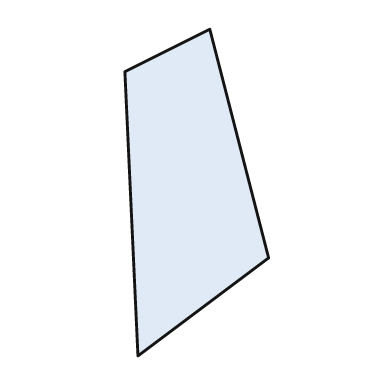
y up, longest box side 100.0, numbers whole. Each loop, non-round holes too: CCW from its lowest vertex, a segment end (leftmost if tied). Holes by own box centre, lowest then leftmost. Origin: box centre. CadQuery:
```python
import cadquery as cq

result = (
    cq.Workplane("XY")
    .moveTo(-18.0, -50.0)
    .lineTo(22.0, -20.0)
    .lineTo(4.0, 50.0)
    .lineTo(-22.0, 37.0)
    .close()
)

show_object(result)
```